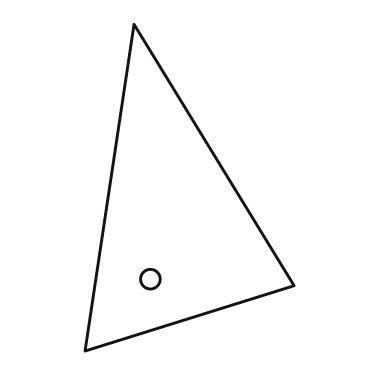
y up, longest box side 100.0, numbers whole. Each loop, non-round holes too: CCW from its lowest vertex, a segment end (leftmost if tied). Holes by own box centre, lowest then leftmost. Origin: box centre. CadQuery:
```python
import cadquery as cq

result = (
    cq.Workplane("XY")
    .moveTo(-32.0, -50.0)
    .lineTo(32.0, -30.0)
    .lineTo(-17.0, 50.0)
    .close()
    .moveTo(-12.0, -28.0)
    .circle(3.0)
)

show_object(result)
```